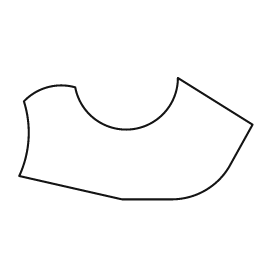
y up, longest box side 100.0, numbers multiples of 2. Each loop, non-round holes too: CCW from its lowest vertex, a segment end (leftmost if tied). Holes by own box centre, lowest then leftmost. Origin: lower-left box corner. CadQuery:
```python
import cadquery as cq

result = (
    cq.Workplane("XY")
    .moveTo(44.0, 0.0)
    .lineTo(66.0, 0.0)
    .threePointArc((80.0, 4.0), (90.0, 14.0))
    .lineTo(100.0, 32.0)
    .lineTo(68.0, 52.0)
    .threePointArc((48.0, 30.0), (24.0, 48.0))
    .threePointArc((12.0, 48.0), (2.0, 42.0))
    .threePointArc((4.0, 26.0), (0.0, 10.0))
    .close()
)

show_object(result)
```